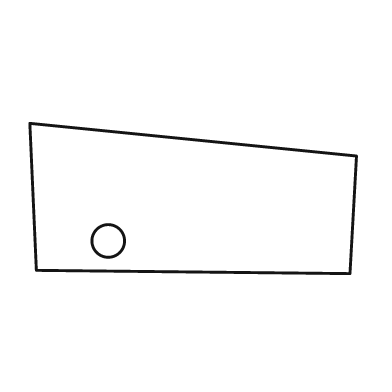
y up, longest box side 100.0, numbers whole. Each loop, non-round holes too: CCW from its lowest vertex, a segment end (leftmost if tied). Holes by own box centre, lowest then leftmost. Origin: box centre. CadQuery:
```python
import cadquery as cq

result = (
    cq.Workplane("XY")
    .moveTo(48.0, -23.0)
    .lineTo(50.0, 13.0)
    .lineTo(-50.0, 23.0)
    .lineTo(-48.0, -22.0)
    .close()
    .moveTo(-26.0, -13.0)
    .circle(5.0)
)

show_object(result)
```